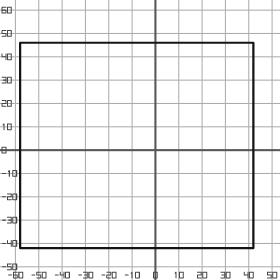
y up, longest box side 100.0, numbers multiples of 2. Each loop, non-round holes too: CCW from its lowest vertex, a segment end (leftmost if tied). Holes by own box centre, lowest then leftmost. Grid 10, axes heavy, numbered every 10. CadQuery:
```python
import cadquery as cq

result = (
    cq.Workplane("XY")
    .moveTo(-58.0, -42.0)
    .lineTo(42.0, -42.0)
    .lineTo(42.0, 46.0)
    .lineTo(-58.0, 46.0)
    .close()
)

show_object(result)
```